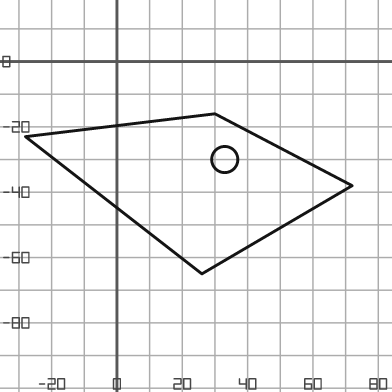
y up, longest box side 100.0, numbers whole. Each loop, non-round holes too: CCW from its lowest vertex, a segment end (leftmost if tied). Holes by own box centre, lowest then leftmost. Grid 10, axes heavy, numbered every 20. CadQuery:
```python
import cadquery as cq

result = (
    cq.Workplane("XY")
    .moveTo(26.0, -65.0)
    .lineTo(72.0, -38.0)
    .lineTo(30.0, -16.0)
    .lineTo(-28.0, -23.0)
    .close()
    .moveTo(33.0, -30.0)
    .circle(4.0)
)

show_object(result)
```